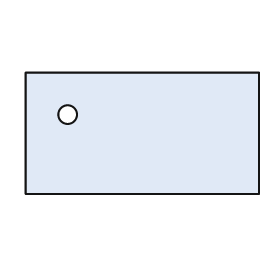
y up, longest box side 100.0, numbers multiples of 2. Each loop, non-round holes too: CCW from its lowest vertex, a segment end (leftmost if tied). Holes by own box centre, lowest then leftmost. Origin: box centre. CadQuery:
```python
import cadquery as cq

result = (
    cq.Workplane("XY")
    .moveTo(-50.0, -26.0)
    .lineTo(50.0, -26.0)
    .lineTo(50.0, 26.0)
    .lineTo(-50.0, 26.0)
    .close()
    .moveTo(-32.0, 8.0)
    .circle(4.0)
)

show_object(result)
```